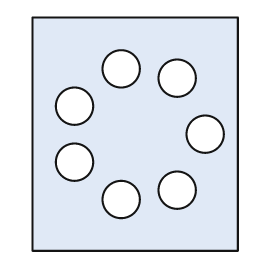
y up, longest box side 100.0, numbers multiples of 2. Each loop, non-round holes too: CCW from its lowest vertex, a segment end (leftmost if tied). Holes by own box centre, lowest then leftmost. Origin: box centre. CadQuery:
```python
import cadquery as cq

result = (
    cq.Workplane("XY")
    .moveTo(-44.0, -50.0)
    .lineTo(44.0, -50.0)
    .lineTo(44.0, 50.0)
    .lineTo(-44.0, 50.0)
    .close()
    .moveTo(-6.0, -28.0)
    .circle(8.0)
    .moveTo(18.0, -24.0)
    .circle(8.0)
    .moveTo(-26.0, -12.0)
    .circle(8.0)
    .moveTo(30.0, 0.0)
    .circle(8.0)
    .moveTo(-26.0, 12.0)
    .circle(8.0)
    .moveTo(18.0, 24.0)
    .circle(8.0)
    .moveTo(-6.0, 28.0)
    .circle(8.0)
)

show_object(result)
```